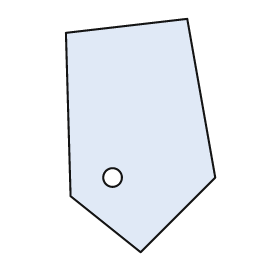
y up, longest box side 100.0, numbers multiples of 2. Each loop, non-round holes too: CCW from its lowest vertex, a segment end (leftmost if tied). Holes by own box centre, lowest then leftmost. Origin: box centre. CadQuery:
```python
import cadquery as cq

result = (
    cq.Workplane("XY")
    .moveTo(0.0, -50.0)
    .lineTo(32.0, -18.0)
    .lineTo(20.0, 50.0)
    .lineTo(-32.0, 44.0)
    .lineTo(-30.0, -26.0)
    .close()
    .moveTo(-12.0, -18.0)
    .circle(4.0)
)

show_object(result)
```